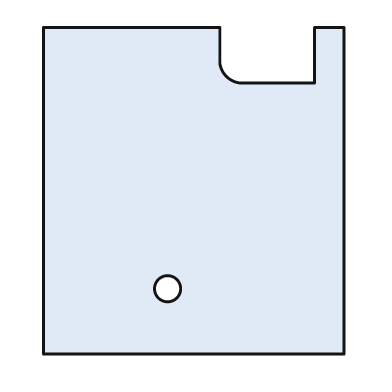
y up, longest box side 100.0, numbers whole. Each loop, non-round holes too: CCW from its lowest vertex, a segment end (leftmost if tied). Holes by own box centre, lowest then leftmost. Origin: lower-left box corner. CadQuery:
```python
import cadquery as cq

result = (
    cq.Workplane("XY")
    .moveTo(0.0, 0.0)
    .lineTo(92.0, 0.0)
    .lineTo(92.0, 100.0)
    .lineTo(83.0, 100.0)
    .lineTo(83.0, 83.0)
    .lineTo(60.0, 83.0)
    .threePointArc((56.0, 85.0), (54.0, 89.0))
    .lineTo(54.0, 100.0)
    .lineTo(0.0, 100.0)
    .close()
    .moveTo(38.0, 20.0)
    .circle(4.0)
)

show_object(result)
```